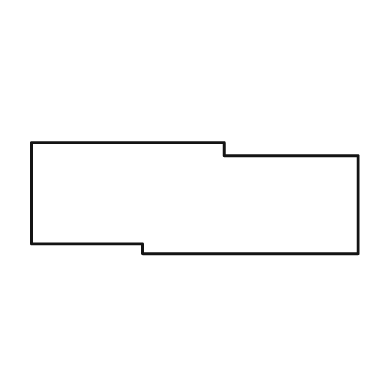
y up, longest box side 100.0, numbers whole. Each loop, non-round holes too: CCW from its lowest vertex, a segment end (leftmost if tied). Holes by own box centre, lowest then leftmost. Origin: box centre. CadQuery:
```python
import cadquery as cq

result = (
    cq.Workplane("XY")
    .moveTo(-16.0, -17.0)
    .lineTo(50.0, -17.0)
    .lineTo(50.0, 13.0)
    .lineTo(9.0, 13.0)
    .lineTo(9.0, 17.0)
    .lineTo(-50.0, 17.0)
    .lineTo(-50.0, -14.0)
    .lineTo(-16.0, -14.0)
    .close()
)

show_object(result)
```